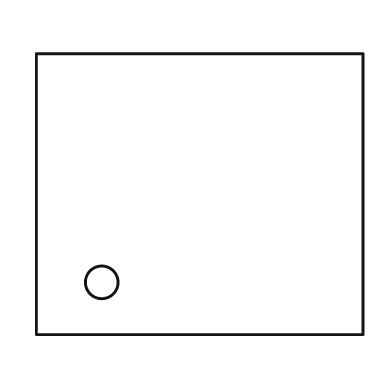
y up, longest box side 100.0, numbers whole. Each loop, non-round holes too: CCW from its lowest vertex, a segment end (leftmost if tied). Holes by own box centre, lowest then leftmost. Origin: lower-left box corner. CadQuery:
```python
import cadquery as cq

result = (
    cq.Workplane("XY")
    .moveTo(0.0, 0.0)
    .lineTo(100.0, 0.0)
    .lineTo(100.0, 86.0)
    .lineTo(0.0, 86.0)
    .close()
    .moveTo(20.0, 16.0)
    .circle(5.0)
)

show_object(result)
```